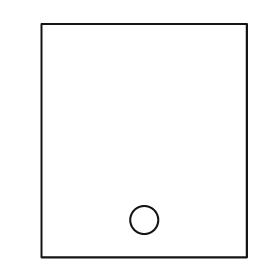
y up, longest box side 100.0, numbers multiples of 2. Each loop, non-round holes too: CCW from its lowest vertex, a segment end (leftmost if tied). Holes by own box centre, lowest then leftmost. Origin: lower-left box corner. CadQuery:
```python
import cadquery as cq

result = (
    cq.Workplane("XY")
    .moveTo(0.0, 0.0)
    .lineTo(88.0, 0.0)
    .lineTo(88.0, 100.0)
    .lineTo(0.0, 100.0)
    .close()
    .moveTo(44.0, 16.0)
    .circle(6.0)
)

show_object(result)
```